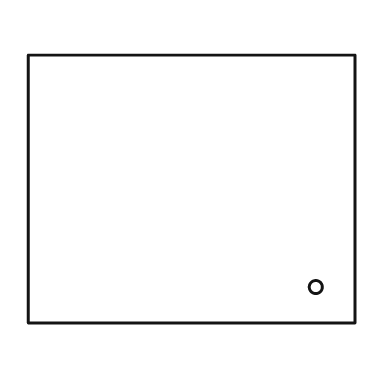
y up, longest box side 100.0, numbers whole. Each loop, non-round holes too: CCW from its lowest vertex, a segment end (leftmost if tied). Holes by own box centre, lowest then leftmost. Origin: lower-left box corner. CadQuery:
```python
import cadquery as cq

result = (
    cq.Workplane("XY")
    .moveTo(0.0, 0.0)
    .lineTo(100.0, 0.0)
    .lineTo(100.0, 82.0)
    .lineTo(0.0, 82.0)
    .close()
    .moveTo(88.0, 11.0)
    .circle(2.0)
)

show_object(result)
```